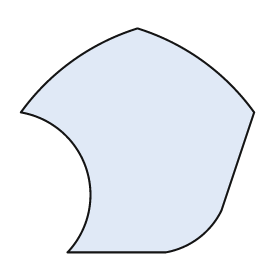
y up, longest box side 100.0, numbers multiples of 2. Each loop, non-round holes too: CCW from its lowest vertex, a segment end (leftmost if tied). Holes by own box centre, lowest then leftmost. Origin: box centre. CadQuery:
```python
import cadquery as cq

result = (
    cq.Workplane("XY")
    .moveTo(-30.0, -48.0)
    .lineTo(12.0, -48.0)
    .threePointArc((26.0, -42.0), (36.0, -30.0))
    .lineTo(50.0, 12.0)
    .threePointArc((28.0, 34.0), (0.0, 48.0))
    .threePointArc((-28.0, 34.0), (-50.0, 12.0))
    .threePointArc((-22.0, -12.0), (-30.0, -48.0))
    .close()
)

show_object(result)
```